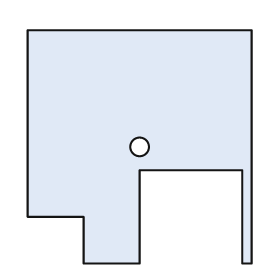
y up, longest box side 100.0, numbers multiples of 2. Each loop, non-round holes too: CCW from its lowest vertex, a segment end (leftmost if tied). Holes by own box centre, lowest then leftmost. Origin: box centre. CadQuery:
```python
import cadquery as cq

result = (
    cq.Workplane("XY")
    .moveTo(-24.0, -50.0)
    .lineTo(0.0, -50.0)
    .lineTo(0.0, -10.0)
    .lineTo(44.0, -10.0)
    .lineTo(44.0, -50.0)
    .lineTo(48.0, -50.0)
    .lineTo(48.0, 50.0)
    .lineTo(-48.0, 50.0)
    .lineTo(-48.0, -30.0)
    .lineTo(-24.0, -30.0)
    .close()
    .moveTo(0.0, 0.0)
    .circle(4.0)
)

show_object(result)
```